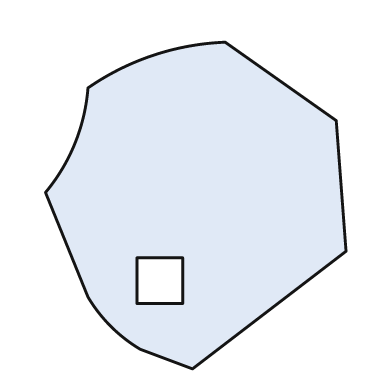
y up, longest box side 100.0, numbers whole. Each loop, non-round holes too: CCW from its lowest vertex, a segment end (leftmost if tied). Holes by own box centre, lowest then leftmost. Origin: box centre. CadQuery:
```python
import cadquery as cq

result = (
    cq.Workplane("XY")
    .moveTo(-1.0, -50.0)
    .lineTo(46.0, -14.0)
    .lineTo(43.0, 26.0)
    .lineTo(9.0, 50.0)
    .threePointArc((-13.0, 46.0), (-33.0, 36.0))
    .threePointArc((-37.0, 19.0), (-46.0, 4.0))
    .lineTo(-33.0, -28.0)
    .threePointArc((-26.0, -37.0), (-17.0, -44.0))
    .close()
    .moveTo(-18.0, -30.0)
    .lineTo(-4.0, -30.0)
    .lineTo(-4.0, -16.0)
    .lineTo(-18.0, -16.0)
    .close()
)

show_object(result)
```